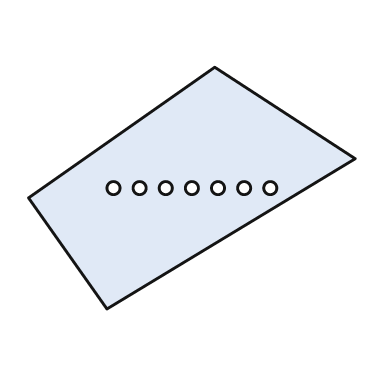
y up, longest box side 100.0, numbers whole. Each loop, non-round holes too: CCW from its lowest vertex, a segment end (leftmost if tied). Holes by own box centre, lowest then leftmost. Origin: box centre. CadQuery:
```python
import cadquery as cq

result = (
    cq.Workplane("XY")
    .moveTo(-26.0, -37.0)
    .lineTo(50.0, 9.0)
    .lineTo(7.0, 37.0)
    .lineTo(-50.0, -3.0)
    .close()
    .moveTo(-24.0, 0.0)
    .circle(2.0)
    .moveTo(-16.0, 0.0)
    .circle(2.0)
    .moveTo(-8.0, 0.0)
    .circle(2.0)
    .moveTo(0.0, 0.0)
    .circle(2.0)
    .moveTo(8.0, 0.0)
    .circle(2.0)
    .moveTo(16.0, 0.0)
    .circle(2.0)
    .moveTo(24.0, 0.0)
    .circle(2.0)
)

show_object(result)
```